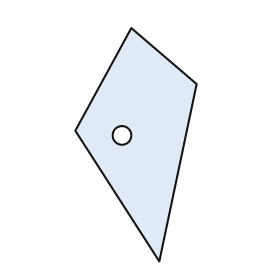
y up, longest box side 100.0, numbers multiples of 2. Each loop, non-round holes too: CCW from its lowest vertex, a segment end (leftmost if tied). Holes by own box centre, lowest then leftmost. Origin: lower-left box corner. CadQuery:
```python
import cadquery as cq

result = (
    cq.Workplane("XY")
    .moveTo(36.0, 0.0)
    .lineTo(52.0, 76.0)
    .lineTo(24.0, 100.0)
    .lineTo(0.0, 56.0)
    .close()
    .moveTo(20.0, 54.0)
    .circle(4.0)
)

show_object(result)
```